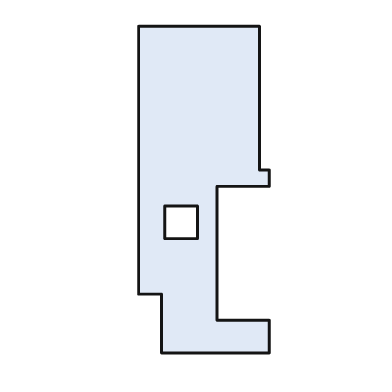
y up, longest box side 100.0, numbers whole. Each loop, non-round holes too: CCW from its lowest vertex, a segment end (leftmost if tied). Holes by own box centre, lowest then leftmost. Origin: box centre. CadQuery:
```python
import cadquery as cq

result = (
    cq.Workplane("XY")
    .moveTo(-13.0, -50.0)
    .lineTo(20.0, -50.0)
    .lineTo(20.0, -40.0)
    .lineTo(4.0, -40.0)
    .lineTo(4.0, 1.0)
    .lineTo(20.0, 1.0)
    .lineTo(20.0, 6.0)
    .lineTo(17.0, 6.0)
    .lineTo(17.0, 50.0)
    .lineTo(-20.0, 50.0)
    .lineTo(-20.0, -32.0)
    .lineTo(-13.0, -32.0)
    .close()
    .moveTo(-12.0, -15.0)
    .lineTo(-2.0, -15.0)
    .lineTo(-2.0, -5.0)
    .lineTo(-12.0, -5.0)
    .close()
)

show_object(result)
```